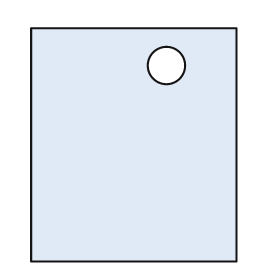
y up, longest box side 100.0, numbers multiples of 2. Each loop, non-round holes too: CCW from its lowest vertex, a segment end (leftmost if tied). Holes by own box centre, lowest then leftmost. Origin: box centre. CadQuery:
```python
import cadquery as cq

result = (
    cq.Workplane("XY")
    .moveTo(-44.0, -50.0)
    .lineTo(44.0, -50.0)
    .lineTo(44.0, 50.0)
    .lineTo(-44.0, 50.0)
    .close()
    .moveTo(14.0, 34.0)
    .circle(8.0)
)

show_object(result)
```